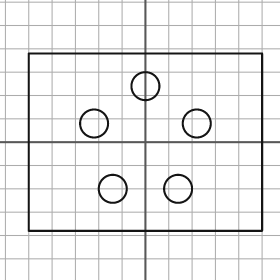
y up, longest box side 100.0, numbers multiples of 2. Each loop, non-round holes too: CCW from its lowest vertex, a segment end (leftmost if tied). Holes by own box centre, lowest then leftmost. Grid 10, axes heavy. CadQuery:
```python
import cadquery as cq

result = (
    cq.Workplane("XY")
    .moveTo(-50.0, -38.0)
    .lineTo(50.0, -38.0)
    .lineTo(50.0, 38.0)
    .lineTo(-50.0, 38.0)
    .close()
    .moveTo(-14.0, -20.0)
    .circle(6.0)
    .moveTo(14.0, -20.0)
    .circle(6.0)
    .moveTo(-22.0, 8.0)
    .circle(6.0)
    .moveTo(22.0, 8.0)
    .circle(6.0)
    .moveTo(0.0, 24.0)
    .circle(6.0)
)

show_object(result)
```